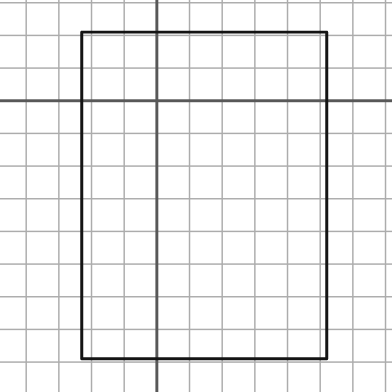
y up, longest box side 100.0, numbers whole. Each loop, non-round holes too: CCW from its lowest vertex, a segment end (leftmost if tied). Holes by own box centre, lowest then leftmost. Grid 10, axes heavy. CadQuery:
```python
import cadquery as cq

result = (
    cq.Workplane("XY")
    .moveTo(-23.0, -79.0)
    .lineTo(52.0, -79.0)
    .lineTo(52.0, 21.0)
    .lineTo(-23.0, 21.0)
    .close()
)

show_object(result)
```